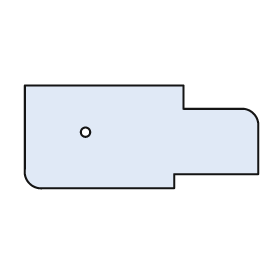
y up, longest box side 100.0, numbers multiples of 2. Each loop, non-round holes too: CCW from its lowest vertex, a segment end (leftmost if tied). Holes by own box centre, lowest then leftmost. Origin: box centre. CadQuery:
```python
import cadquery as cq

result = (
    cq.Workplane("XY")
    .moveTo(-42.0, -22.0)
    .lineTo(14.0, -22.0)
    .lineTo(14.0, -16.0)
    .lineTo(50.0, -16.0)
    .lineTo(50.0, 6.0)
    .threePointArc((48.0, 10.0), (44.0, 12.0))
    .lineTo(18.0, 12.0)
    .lineTo(18.0, 22.0)
    .lineTo(-50.0, 22.0)
    .lineTo(-50.0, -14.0)
    .threePointArc((-48.0, -20.0), (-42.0, -22.0))
    .close()
    .moveTo(-24.0, 2.0)
    .circle(2.0)
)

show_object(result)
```